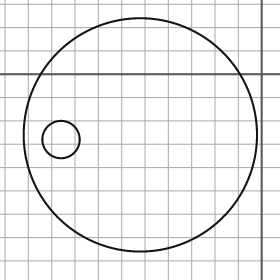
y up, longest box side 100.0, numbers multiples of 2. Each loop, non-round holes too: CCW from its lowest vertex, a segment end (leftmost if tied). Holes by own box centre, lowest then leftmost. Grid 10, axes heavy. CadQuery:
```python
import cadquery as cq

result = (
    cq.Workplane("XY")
    .moveTo(-52.0, -26.0)
    .circle(50.0)
    .moveTo(-86.0, -28.0)
    .circle(8.0)
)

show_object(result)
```